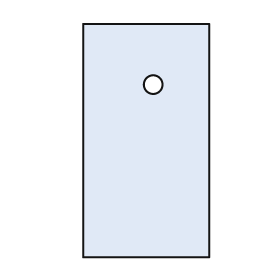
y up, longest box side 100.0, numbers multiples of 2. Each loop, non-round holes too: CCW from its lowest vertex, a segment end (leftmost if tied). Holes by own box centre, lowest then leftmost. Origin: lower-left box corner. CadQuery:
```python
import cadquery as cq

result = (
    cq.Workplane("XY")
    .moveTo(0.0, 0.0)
    .lineTo(54.0, 0.0)
    .lineTo(54.0, 100.0)
    .lineTo(0.0, 100.0)
    .close()
    .moveTo(30.0, 74.0)
    .circle(4.0)
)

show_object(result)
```